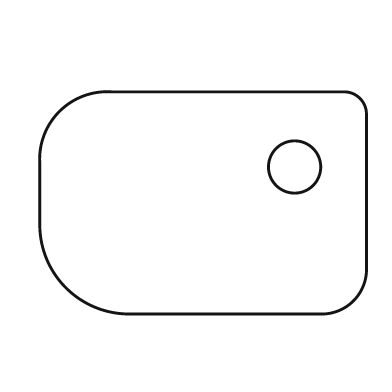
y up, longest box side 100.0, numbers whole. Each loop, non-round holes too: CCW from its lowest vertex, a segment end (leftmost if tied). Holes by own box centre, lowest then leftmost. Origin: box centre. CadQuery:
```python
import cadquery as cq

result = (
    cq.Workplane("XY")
    .moveTo(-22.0, -34.0)
    .lineTo(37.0, -34.0)
    .threePointArc((46.0, -30.0), (50.0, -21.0))
    .lineTo(50.0, 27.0)
    .threePointArc((48.0, 32.0), (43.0, 34.0))
    .lineTo(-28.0, 34.0)
    .threePointArc((-44.0, 28.0), (-50.0, 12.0))
    .lineTo(-50.0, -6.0)
    .threePointArc((-42.0, -26.0), (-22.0, -34.0))
    .close()
    .moveTo(28.0, 11.0)
    .circle(8.0)
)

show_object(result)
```